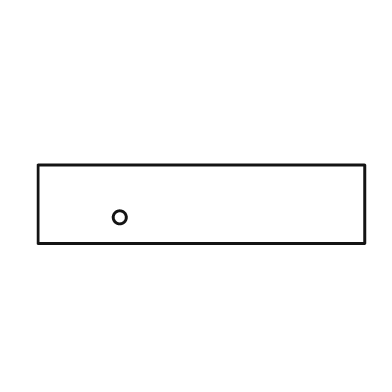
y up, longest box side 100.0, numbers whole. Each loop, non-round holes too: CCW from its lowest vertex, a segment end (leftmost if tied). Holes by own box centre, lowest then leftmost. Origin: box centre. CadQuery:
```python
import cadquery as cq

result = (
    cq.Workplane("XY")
    .moveTo(-50.0, -12.0)
    .lineTo(50.0, -12.0)
    .lineTo(50.0, 12.0)
    .lineTo(-50.0, 12.0)
    .close()
    .moveTo(-25.0, -4.0)
    .circle(2.0)
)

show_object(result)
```